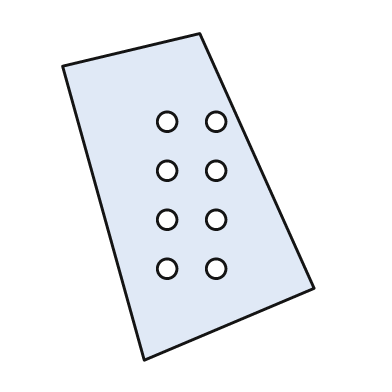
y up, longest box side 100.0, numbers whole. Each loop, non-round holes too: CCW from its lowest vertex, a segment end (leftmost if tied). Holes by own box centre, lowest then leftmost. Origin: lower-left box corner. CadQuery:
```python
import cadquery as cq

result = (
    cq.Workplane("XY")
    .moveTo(25.0, 0.0)
    .lineTo(77.0, 22.0)
    .lineTo(42.0, 100.0)
    .lineTo(0.0, 90.0)
    .close()
    .moveTo(32.0, 28.0)
    .circle(3.0)
    .moveTo(47.0, 28.0)
    .circle(3.0)
    .moveTo(32.0, 43.0)
    .circle(3.0)
    .moveTo(47.0, 43.0)
    .circle(3.0)
    .moveTo(32.0, 58.0)
    .circle(3.0)
    .moveTo(47.0, 58.0)
    .circle(3.0)
    .moveTo(32.0, 73.0)
    .circle(3.0)
    .moveTo(47.0, 73.0)
    .circle(3.0)
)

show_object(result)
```